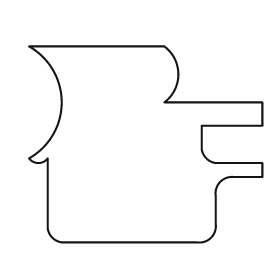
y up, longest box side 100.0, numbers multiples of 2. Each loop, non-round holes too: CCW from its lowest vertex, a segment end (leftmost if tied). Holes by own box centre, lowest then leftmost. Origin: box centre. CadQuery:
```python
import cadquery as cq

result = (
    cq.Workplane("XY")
    .moveTo(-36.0, -42.0)
    .lineTo(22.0, -42.0)
    .threePointArc((28.0, -40.0), (30.0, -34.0))
    .lineTo(30.0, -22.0)
    .threePointArc((32.0, -16.0), (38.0, -14.0))
    .lineTo(50.0, -14.0)
    .lineTo(50.0, -8.0)
    .lineTo(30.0, -8.0)
    .threePointArc((26.0, -6.0), (24.0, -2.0))
    .lineTo(24.0, 8.0)
    .lineTo(50.0, 8.0)
    .lineTo(50.0, 18.0)
    .lineTo(8.0, 18.0)
    .threePointArc((14.0, 30.0), (8.0, 42.0))
    .lineTo(-50.0, 42.0)
    .threePointArc((-36.0, 18.0), (-50.0, -6.0))
    .threePointArc((-46.0, -8.0), (-42.0, -6.0))
    .lineTo(-42.0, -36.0)
    .threePointArc((-40.0, -40.0), (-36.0, -42.0))
    .close()
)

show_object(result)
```